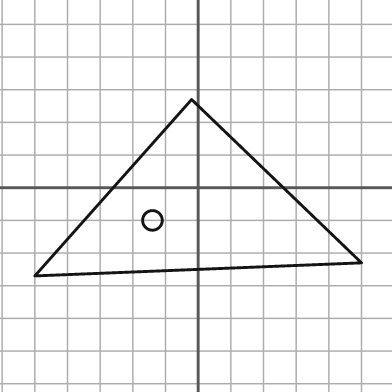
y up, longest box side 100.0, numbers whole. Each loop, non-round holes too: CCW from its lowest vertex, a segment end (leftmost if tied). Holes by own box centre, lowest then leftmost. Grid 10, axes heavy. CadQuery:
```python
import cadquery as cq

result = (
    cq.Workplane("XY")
    .moveTo(-50.0, -27.0)
    .lineTo(50.0, -23.0)
    .lineTo(-2.0, 27.0)
    .close()
    .moveTo(-14.0, -10.0)
    .circle(3.0)
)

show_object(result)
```